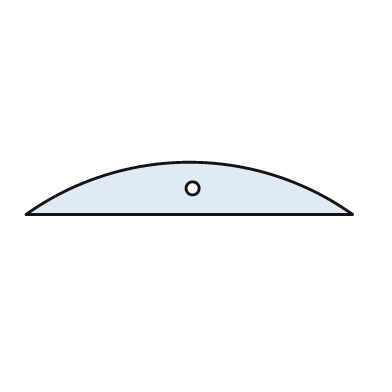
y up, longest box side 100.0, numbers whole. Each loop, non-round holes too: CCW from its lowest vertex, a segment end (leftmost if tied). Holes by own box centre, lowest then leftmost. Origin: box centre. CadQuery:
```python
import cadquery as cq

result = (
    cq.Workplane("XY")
    .moveTo(-50.0, -8.0)
    .lineTo(50.0, -8.0)
    .threePointArc((0.0, 8.0), (-50.0, -8.0))
    .close()
    .moveTo(1.0, 0.0)
    .circle(2.0)
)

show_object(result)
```